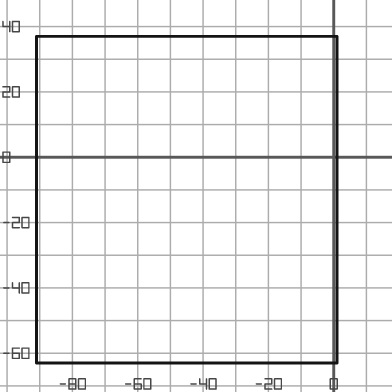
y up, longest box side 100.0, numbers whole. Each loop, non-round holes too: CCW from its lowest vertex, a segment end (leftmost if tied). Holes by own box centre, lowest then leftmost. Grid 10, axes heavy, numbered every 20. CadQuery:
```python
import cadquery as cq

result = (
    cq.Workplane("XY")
    .moveTo(-91.0, -63.0)
    .lineTo(1.0, -63.0)
    .lineTo(1.0, 37.0)
    .lineTo(-91.0, 37.0)
    .close()
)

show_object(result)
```